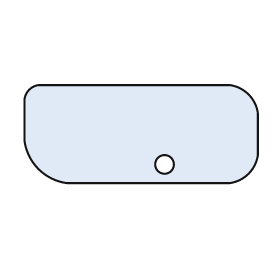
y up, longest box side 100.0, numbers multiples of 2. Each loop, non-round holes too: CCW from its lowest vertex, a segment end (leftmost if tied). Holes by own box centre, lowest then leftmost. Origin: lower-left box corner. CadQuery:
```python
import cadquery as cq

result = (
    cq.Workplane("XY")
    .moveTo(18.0, 0.0)
    .lineTo(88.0, 0.0)
    .threePointArc((96.0, 4.0), (100.0, 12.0))
    .lineTo(100.0, 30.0)
    .threePointArc((96.0, 38.0), (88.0, 42.0))
    .lineTo(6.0, 42.0)
    .threePointArc((2.0, 40.0), (0.0, 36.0))
    .lineTo(0.0, 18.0)
    .threePointArc((6.0, 6.0), (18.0, 0.0))
    .close()
    .moveTo(60.0, 8.0)
    .circle(4.0)
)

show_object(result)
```